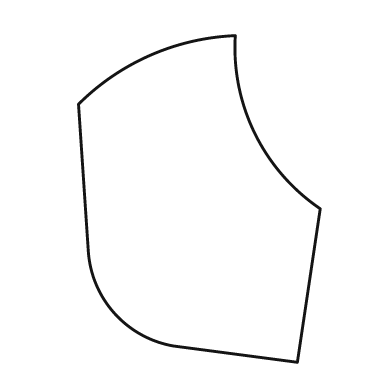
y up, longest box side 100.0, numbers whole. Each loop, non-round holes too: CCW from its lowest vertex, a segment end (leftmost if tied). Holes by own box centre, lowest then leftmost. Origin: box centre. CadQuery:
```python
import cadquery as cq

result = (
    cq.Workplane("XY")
    .moveTo(30.0, -50.0)
    .lineTo(37.0, -3.0)
    .threePointArc((17.0, 20.0), (11.0, 50.0))
    .threePointArc((-15.0, 44.0), (-37.0, 29.0))
    .lineTo(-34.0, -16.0)
    .threePointArc((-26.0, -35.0), (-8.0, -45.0))
    .close()
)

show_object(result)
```